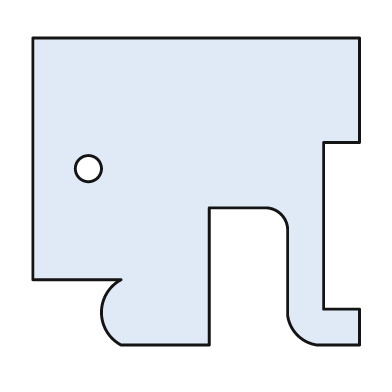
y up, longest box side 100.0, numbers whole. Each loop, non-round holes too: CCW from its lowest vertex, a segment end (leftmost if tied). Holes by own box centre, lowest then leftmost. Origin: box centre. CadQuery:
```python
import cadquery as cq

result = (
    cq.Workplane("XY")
    .moveTo(-23.0, -47.0)
    .lineTo(4.0, -47.0)
    .lineTo(4.0, -5.0)
    .lineTo(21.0, -5.0)
    .threePointArc((26.0, -7.0), (28.0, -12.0))
    .lineTo(28.0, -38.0)
    .threePointArc((31.0, -44.0), (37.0, -47.0))
    .lineTo(50.0, -47.0)
    .lineTo(50.0, -36.0)
    .lineTo(39.0, -36.0)
    .lineTo(39.0, 15.0)
    .lineTo(50.0, 15.0)
    .lineTo(50.0, 47.0)
    .lineTo(-50.0, 47.0)
    .lineTo(-50.0, -27.0)
    .lineTo(-23.0, -27.0)
    .threePointArc((-29.0, -37.0), (-23.0, -47.0))
    .close()
    .moveTo(-33.0, 7.0)
    .circle(4.0)
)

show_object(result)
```